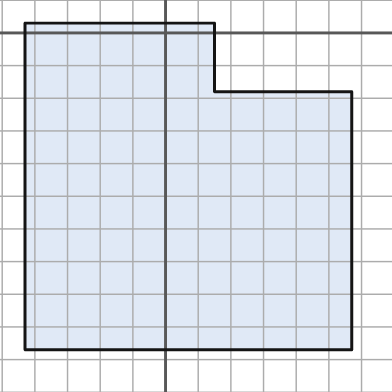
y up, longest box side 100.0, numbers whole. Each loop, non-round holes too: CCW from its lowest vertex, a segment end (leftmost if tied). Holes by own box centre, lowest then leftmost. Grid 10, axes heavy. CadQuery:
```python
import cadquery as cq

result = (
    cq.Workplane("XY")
    .moveTo(-43.0, -97.0)
    .lineTo(57.0, -97.0)
    .lineTo(57.0, -18.0)
    .lineTo(15.0, -18.0)
    .lineTo(15.0, 3.0)
    .lineTo(-43.0, 3.0)
    .close()
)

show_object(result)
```